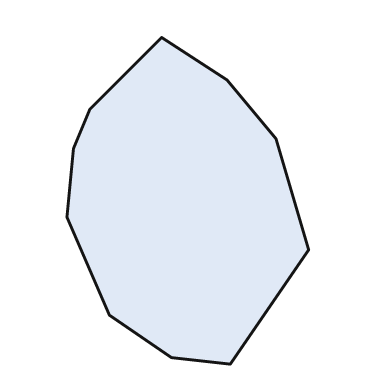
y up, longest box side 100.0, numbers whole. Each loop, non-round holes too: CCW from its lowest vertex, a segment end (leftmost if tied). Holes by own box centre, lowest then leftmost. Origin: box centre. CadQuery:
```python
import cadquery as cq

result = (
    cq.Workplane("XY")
    .moveTo(13.0, -50.0)
    .lineTo(37.0, -15.0)
    .lineTo(27.0, 19.0)
    .lineTo(12.0, 37.0)
    .lineTo(-8.0, 50.0)
    .lineTo(-30.0, 28.0)
    .lineTo(-35.0, 16.0)
    .lineTo(-37.0, -5.0)
    .lineTo(-24.0, -35.0)
    .lineTo(-5.0, -48.0)
    .close()
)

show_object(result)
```